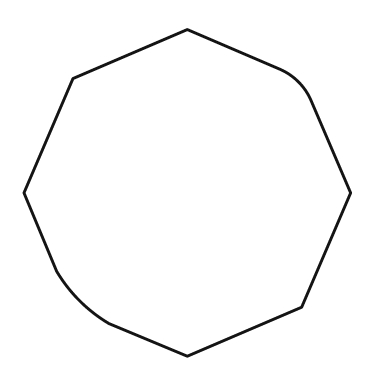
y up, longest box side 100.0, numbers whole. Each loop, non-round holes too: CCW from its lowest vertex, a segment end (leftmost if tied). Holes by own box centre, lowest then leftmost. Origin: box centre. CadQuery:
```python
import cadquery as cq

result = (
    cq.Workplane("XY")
    .moveTo(0.0, -50.0)
    .lineTo(35.0, -35.0)
    .lineTo(50.0, 0.0)
    .lineTo(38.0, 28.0)
    .threePointArc((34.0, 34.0), (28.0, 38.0))
    .lineTo(0.0, 50.0)
    .lineTo(-35.0, 35.0)
    .lineTo(-50.0, 0.0)
    .lineTo(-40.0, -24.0)
    .threePointArc((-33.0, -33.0), (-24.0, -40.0))
    .close()
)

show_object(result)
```